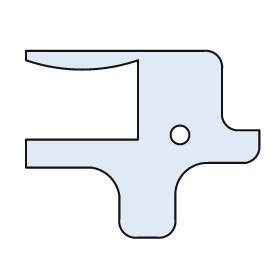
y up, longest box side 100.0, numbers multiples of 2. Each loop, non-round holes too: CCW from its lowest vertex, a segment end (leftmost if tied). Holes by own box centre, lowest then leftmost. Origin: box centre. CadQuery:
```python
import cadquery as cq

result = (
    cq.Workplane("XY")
    .moveTo(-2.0, -40.0)
    .lineTo(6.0, -40.0)
    .threePointArc((12.0, -38.0), (14.0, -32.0))
    .lineTo(14.0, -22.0)
    .threePointArc((18.0, -12.0), (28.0, -8.0))
    .lineTo(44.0, -8.0)
    .threePointArc((48.0, -6.0), (50.0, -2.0))
    .lineTo(50.0, 6.0)
    .lineTo(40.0, 6.0)
    .threePointArc((36.0, 8.0), (34.0, 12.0))
    .lineTo(34.0, 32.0)
    .threePointArc((32.0, 38.0), (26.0, 40.0))
    .lineTo(-50.0, 40.0)
    .lineTo(-50.0, 36.0)
    .threePointArc((-26.0, 32.0), (-2.0, 36.0))
    .lineTo(-2.0, 2.0)
    .lineTo(-50.0, 2.0)
    .lineTo(-50.0, -10.0)
    .lineTo(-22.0, -10.0)
    .threePointArc((-14.0, -14.0), (-10.0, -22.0))
    .lineTo(-10.0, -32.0)
    .threePointArc((-8.0, -38.0), (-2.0, -40.0))
    .close()
    .moveTo(16.0, 4.0)
    .circle(4.0)
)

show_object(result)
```